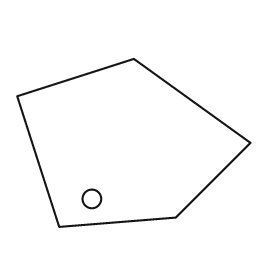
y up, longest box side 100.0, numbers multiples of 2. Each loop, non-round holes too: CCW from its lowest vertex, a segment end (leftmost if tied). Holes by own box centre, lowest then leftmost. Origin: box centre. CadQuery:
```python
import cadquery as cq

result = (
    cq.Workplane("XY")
    .moveTo(-32.0, -36.0)
    .lineTo(18.0, -32.0)
    .lineTo(50.0, 0.0)
    .lineTo(0.0, 36.0)
    .lineTo(-50.0, 20.0)
    .close()
    .moveTo(-18.0, -24.0)
    .circle(4.0)
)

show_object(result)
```